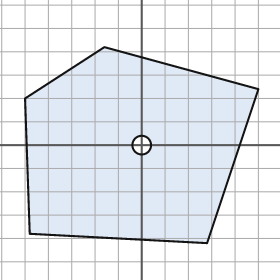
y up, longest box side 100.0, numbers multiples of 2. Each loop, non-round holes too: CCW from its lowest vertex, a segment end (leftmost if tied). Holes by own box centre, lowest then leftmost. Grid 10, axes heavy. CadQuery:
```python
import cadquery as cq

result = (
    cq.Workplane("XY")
    .moveTo(28.0, -42.0)
    .lineTo(50.0, 24.0)
    .lineTo(-16.0, 42.0)
    .lineTo(-50.0, 20.0)
    .lineTo(-48.0, -38.0)
    .close()
    .moveTo(0.0, 0.0)
    .circle(4.0)
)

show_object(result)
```